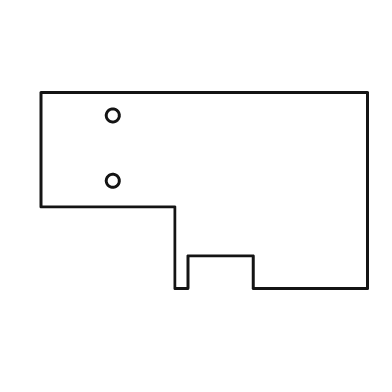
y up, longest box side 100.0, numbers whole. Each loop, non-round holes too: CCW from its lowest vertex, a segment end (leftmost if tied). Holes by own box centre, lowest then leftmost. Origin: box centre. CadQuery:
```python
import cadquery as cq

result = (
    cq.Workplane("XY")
    .moveTo(-9.0, -30.0)
    .lineTo(-5.0, -30.0)
    .lineTo(-5.0, -20.0)
    .lineTo(15.0, -20.0)
    .lineTo(15.0, -30.0)
    .lineTo(50.0, -30.0)
    .lineTo(50.0, 30.0)
    .lineTo(-50.0, 30.0)
    .lineTo(-50.0, -5.0)
    .lineTo(-9.0, -5.0)
    .close()
    .moveTo(-28.0, 3.0)
    .circle(2.0)
    .moveTo(-28.0, 23.0)
    .circle(2.0)
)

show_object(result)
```